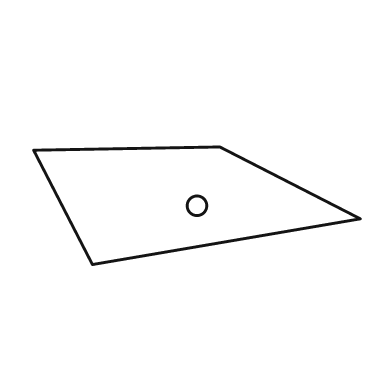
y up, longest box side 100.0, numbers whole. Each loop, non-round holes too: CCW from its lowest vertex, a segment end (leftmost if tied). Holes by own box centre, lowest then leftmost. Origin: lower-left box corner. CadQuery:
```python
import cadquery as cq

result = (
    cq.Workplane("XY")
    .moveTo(18.0, 0.0)
    .lineTo(100.0, 14.0)
    .lineTo(57.0, 36.0)
    .lineTo(0.0, 35.0)
    .close()
    .moveTo(50.0, 18.0)
    .circle(3.0)
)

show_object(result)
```